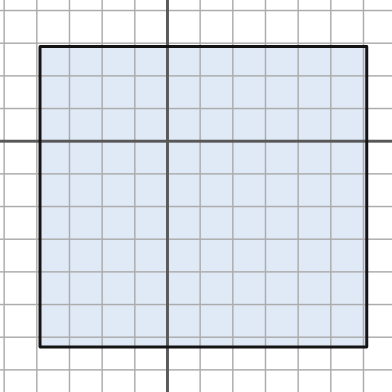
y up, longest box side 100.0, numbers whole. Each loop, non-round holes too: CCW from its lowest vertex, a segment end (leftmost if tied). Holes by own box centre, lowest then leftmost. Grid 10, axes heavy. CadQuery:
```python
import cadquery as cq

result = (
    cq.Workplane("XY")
    .moveTo(-39.0, -63.0)
    .lineTo(61.0, -63.0)
    .lineTo(61.0, 29.0)
    .lineTo(-39.0, 29.0)
    .close()
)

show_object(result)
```